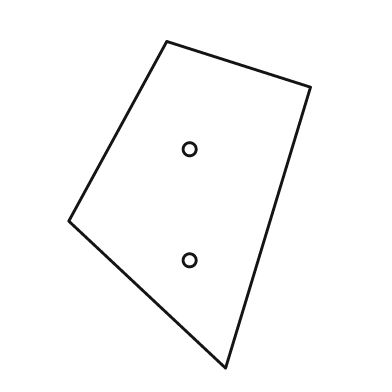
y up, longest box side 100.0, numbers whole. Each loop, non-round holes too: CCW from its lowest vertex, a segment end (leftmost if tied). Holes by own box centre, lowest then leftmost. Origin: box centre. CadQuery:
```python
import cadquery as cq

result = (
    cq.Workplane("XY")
    .moveTo(11.0, -50.0)
    .lineTo(37.0, 36.0)
    .lineTo(-7.0, 50.0)
    .lineTo(-37.0, -5.0)
    .close()
    .moveTo(0.0, -17.0)
    .circle(2.0)
    .moveTo(0.0, 17.0)
    .circle(2.0)
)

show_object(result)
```